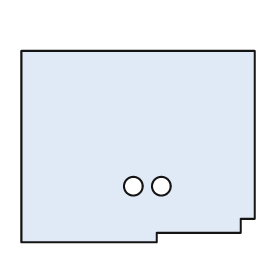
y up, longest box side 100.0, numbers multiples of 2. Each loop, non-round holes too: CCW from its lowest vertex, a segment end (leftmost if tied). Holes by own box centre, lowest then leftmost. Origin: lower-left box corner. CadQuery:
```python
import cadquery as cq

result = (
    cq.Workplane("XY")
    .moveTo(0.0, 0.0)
    .lineTo(58.0, 0.0)
    .lineTo(58.0, 4.0)
    .lineTo(94.0, 4.0)
    .lineTo(94.0, 10.0)
    .lineTo(100.0, 10.0)
    .lineTo(100.0, 82.0)
    .lineTo(0.0, 82.0)
    .close()
    .moveTo(48.0, 24.0)
    .circle(4.0)
    .moveTo(60.0, 24.0)
    .circle(4.0)
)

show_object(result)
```